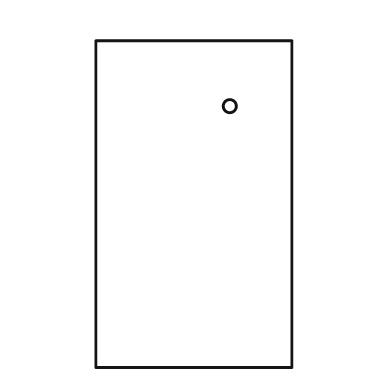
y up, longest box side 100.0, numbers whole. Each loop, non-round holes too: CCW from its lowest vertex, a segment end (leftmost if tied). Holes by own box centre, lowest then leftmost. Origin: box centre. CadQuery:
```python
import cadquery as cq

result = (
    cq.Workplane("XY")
    .moveTo(-30.0, -50.0)
    .lineTo(30.0, -50.0)
    .lineTo(30.0, 50.0)
    .lineTo(-30.0, 50.0)
    .close()
    .moveTo(11.0, 30.0)
    .circle(2.0)
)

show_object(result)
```